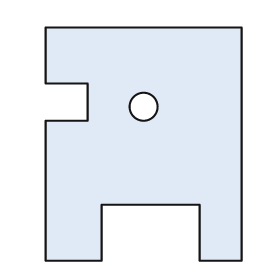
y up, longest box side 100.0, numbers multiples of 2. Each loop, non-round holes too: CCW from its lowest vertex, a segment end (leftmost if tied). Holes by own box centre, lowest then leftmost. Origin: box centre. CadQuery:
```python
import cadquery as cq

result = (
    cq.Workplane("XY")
    .moveTo(-42.0, -50.0)
    .lineTo(-18.0, -50.0)
    .lineTo(-18.0, -26.0)
    .lineTo(24.0, -26.0)
    .lineTo(24.0, -50.0)
    .lineTo(42.0, -50.0)
    .lineTo(42.0, 50.0)
    .lineTo(-42.0, 50.0)
    .lineTo(-42.0, 26.0)
    .lineTo(-24.0, 26.0)
    .lineTo(-24.0, 10.0)
    .lineTo(-42.0, 10.0)
    .close()
    .moveTo(0.0, 16.0)
    .circle(6.0)
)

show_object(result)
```